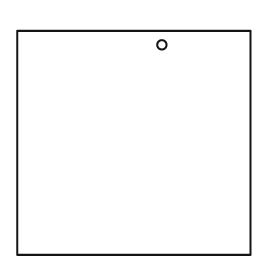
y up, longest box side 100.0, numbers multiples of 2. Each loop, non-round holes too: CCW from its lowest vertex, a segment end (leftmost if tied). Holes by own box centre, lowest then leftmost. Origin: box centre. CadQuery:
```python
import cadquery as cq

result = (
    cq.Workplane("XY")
    .moveTo(-50.0, -48.0)
    .lineTo(50.0, -48.0)
    .lineTo(50.0, 48.0)
    .lineTo(-50.0, 48.0)
    .close()
    .moveTo(12.0, 42.0)
    .circle(2.0)
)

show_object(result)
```